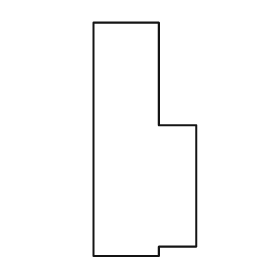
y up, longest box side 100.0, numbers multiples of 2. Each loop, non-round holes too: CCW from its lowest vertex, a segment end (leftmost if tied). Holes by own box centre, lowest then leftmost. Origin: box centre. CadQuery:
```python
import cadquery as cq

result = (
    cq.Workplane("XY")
    .moveTo(-22.0, -50.0)
    .lineTo(6.0, -50.0)
    .lineTo(6.0, -46.0)
    .lineTo(22.0, -46.0)
    .lineTo(22.0, 6.0)
    .lineTo(6.0, 6.0)
    .lineTo(6.0, 50.0)
    .lineTo(-22.0, 50.0)
    .close()
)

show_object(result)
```